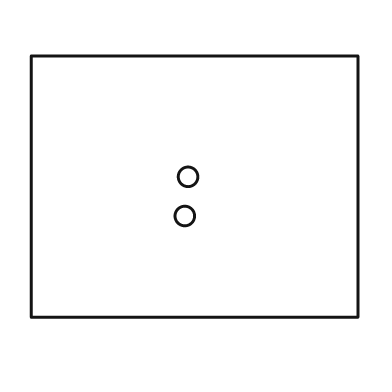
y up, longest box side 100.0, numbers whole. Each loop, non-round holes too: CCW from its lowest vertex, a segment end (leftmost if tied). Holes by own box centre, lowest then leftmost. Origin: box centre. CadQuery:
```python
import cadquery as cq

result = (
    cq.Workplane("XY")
    .moveTo(-50.0, -40.0)
    .lineTo(50.0, -40.0)
    .lineTo(50.0, 40.0)
    .lineTo(-50.0, 40.0)
    .close()
    .moveTo(-3.0, -9.0)
    .circle(3.0)
    .moveTo(-2.0, 3.0)
    .circle(3.0)
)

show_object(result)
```